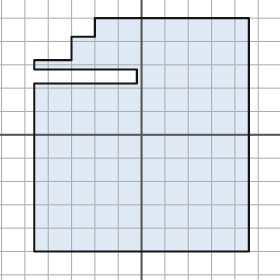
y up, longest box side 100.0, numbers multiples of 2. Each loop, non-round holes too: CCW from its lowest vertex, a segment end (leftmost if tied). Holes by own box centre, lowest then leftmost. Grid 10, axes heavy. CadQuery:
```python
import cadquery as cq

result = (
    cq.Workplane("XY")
    .moveTo(-46.0, -50.0)
    .lineTo(46.0, -50.0)
    .lineTo(46.0, 50.0)
    .lineTo(-20.0, 50.0)
    .lineTo(-20.0, 42.0)
    .lineTo(-30.0, 42.0)
    .lineTo(-30.0, 32.0)
    .lineTo(-46.0, 32.0)
    .lineTo(-46.0, 28.0)
    .lineTo(-2.0, 28.0)
    .lineTo(-2.0, 22.0)
    .lineTo(-46.0, 22.0)
    .close()
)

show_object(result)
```